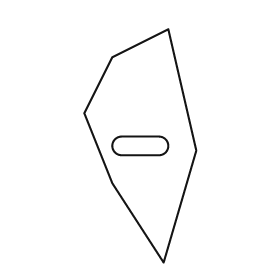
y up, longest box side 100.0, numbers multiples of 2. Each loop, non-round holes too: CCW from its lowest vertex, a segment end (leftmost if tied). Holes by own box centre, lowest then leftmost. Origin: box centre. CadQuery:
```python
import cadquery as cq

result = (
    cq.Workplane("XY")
    .moveTo(10.0, -50.0)
    .lineTo(24.0, -2.0)
    .lineTo(12.0, 50.0)
    .lineTo(-12.0, 38.0)
    .lineTo(-24.0, 14.0)
    .lineTo(-12.0, -16.0)
    .close()
    .moveTo(-8.0, -4.0)
    .lineTo(8.0, -4.0)
    .threePointArc((12.0, 0.0), (8.0, 4.0))
    .lineTo(-8.0, 4.0)
    .threePointArc((-12.0, 0.0), (-8.0, -4.0))
    .close()
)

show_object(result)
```